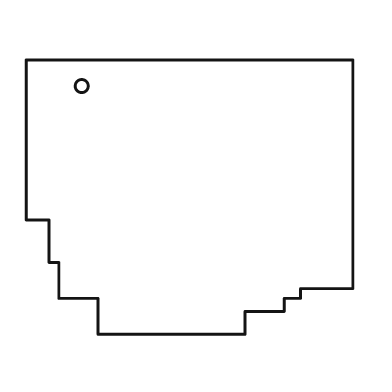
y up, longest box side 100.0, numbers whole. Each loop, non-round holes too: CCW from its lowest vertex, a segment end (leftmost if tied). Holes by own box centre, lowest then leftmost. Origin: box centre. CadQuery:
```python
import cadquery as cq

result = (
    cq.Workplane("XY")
    .moveTo(-28.0, -42.0)
    .lineTo(17.0, -42.0)
    .lineTo(17.0, -35.0)
    .lineTo(29.0, -35.0)
    .lineTo(29.0, -31.0)
    .lineTo(34.0, -31.0)
    .lineTo(34.0, -28.0)
    .lineTo(50.0, -28.0)
    .lineTo(50.0, 42.0)
    .lineTo(-50.0, 42.0)
    .lineTo(-50.0, -7.0)
    .lineTo(-43.0, -7.0)
    .lineTo(-43.0, -20.0)
    .lineTo(-40.0, -20.0)
    .lineTo(-40.0, -31.0)
    .lineTo(-28.0, -31.0)
    .close()
    .moveTo(-33.0, 34.0)
    .circle(2.0)
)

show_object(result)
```